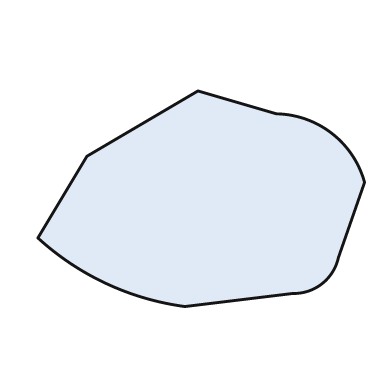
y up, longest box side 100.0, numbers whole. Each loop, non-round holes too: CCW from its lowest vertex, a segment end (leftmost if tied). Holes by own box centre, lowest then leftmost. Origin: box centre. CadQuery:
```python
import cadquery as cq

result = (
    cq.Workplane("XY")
    .moveTo(-5.0, -33.0)
    .lineTo(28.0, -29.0)
    .threePointArc((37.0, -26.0), (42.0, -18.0))
    .lineTo(50.0, 5.0)
    .threePointArc((40.0, 20.0), (23.0, 26.0))
    .lineTo(-1.0, 33.0)
    .lineTo(-35.0, 13.0)
    .lineTo(-50.0, -12.0)
    .threePointArc((-29.0, -26.0), (-5.0, -33.0))
    .close()
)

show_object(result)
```